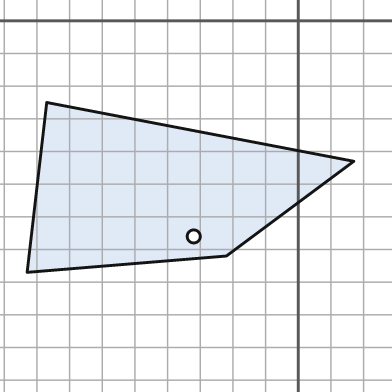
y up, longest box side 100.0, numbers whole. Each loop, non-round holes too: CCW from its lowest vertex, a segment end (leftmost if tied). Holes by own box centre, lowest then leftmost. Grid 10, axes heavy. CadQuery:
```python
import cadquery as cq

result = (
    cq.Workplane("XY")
    .moveTo(-83.0, -77.0)
    .lineTo(-22.0, -72.0)
    .lineTo(17.0, -43.0)
    .lineTo(-77.0, -25.0)
    .close()
    .moveTo(-32.0, -66.0)
    .circle(2.0)
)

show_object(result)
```